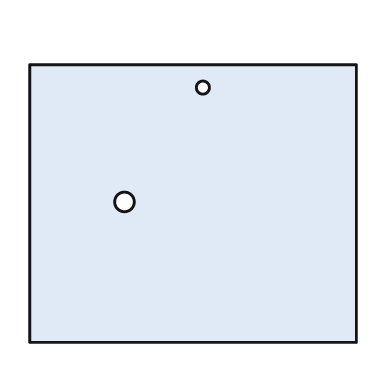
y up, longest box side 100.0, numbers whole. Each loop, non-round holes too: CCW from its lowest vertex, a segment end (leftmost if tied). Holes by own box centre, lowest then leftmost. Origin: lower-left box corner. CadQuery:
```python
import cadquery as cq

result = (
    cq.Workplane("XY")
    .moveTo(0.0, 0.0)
    .lineTo(100.0, 0.0)
    .lineTo(100.0, 85.0)
    .lineTo(0.0, 85.0)
    .close()
    .moveTo(29.0, 43.0)
    .circle(3.0)
    .moveTo(53.0, 78.0)
    .circle(2.0)
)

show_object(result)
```